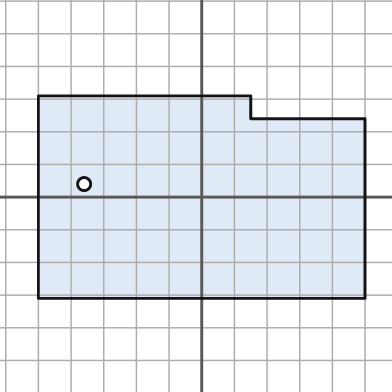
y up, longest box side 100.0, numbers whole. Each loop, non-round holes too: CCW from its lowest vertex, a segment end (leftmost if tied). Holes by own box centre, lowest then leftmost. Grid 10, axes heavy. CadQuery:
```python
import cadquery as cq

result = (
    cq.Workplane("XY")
    .moveTo(-50.0, -31.0)
    .lineTo(50.0, -31.0)
    .lineTo(50.0, 24.0)
    .lineTo(15.0, 24.0)
    .lineTo(15.0, 31.0)
    .lineTo(-50.0, 31.0)
    .close()
    .moveTo(-36.0, 4.0)
    .circle(2.0)
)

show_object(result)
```